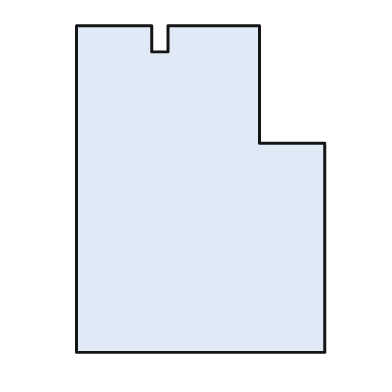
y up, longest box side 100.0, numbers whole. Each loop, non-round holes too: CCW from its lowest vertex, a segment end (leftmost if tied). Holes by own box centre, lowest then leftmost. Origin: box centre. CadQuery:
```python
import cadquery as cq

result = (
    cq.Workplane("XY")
    .moveTo(-38.0, -50.0)
    .lineTo(38.0, -50.0)
    .lineTo(38.0, 14.0)
    .lineTo(18.0, 14.0)
    .lineTo(18.0, 50.0)
    .lineTo(-10.0, 50.0)
    .lineTo(-10.0, 42.0)
    .lineTo(-15.0, 42.0)
    .lineTo(-15.0, 50.0)
    .lineTo(-38.0, 50.0)
    .close()
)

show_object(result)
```